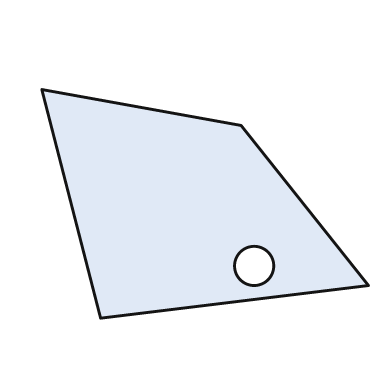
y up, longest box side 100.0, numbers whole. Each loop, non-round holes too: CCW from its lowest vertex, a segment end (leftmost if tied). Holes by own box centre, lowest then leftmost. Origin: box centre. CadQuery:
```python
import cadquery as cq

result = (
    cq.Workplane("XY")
    .moveTo(-32.0, -35.0)
    .lineTo(50.0, -25.0)
    .lineTo(11.0, 24.0)
    .lineTo(-50.0, 35.0)
    .close()
    .moveTo(15.0, -19.0)
    .circle(6.0)
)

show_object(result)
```